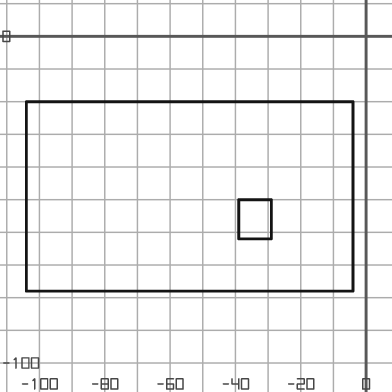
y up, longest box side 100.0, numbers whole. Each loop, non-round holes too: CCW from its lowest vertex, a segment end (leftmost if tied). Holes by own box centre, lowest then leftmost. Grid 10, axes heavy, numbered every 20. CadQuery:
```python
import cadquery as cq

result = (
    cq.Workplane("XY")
    .moveTo(-104.0, -78.0)
    .lineTo(-4.0, -78.0)
    .lineTo(-4.0, -20.0)
    .lineTo(-104.0, -20.0)
    .close()
    .moveTo(-39.0, -62.0)
    .lineTo(-29.0, -62.0)
    .lineTo(-29.0, -50.0)
    .lineTo(-39.0, -50.0)
    .close()
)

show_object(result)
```